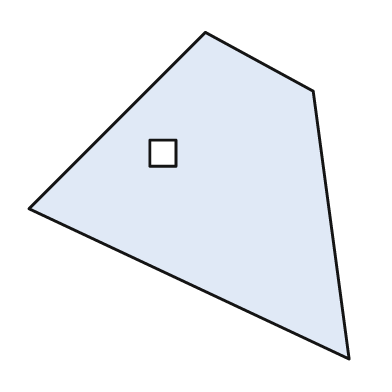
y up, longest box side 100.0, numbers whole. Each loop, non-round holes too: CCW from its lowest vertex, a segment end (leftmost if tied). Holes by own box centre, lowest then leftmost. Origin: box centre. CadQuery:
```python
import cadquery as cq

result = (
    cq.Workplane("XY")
    .moveTo(49.0, -50.0)
    .lineTo(38.0, 32.0)
    .lineTo(5.0, 50.0)
    .lineTo(-49.0, -4.0)
    .close()
    .moveTo(-12.0, 9.0)
    .lineTo(-4.0, 9.0)
    .lineTo(-4.0, 17.0)
    .lineTo(-12.0, 17.0)
    .close()
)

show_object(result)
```